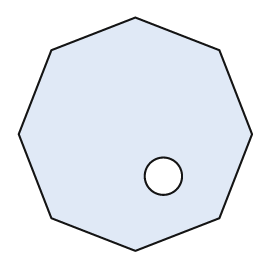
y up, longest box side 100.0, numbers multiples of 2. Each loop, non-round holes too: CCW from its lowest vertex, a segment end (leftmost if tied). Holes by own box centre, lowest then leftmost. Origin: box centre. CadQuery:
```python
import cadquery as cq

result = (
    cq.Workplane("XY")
    .moveTo(0.0, -50.0)
    .lineTo(36.0, -36.0)
    .lineTo(50.0, 0.0)
    .lineTo(36.0, 36.0)
    .lineTo(0.0, 50.0)
    .lineTo(-36.0, 36.0)
    .lineTo(-50.0, 0.0)
    .lineTo(-36.0, -36.0)
    .close()
    .moveTo(12.0, -18.0)
    .circle(8.0)
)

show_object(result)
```